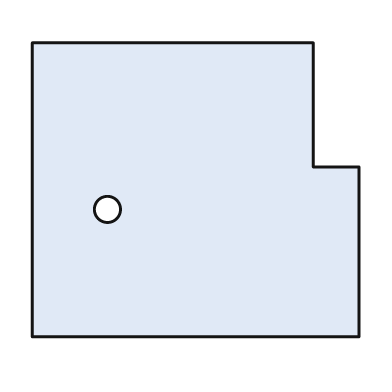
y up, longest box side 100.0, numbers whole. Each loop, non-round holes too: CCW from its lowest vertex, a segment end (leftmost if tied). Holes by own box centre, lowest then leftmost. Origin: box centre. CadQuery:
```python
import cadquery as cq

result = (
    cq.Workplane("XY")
    .moveTo(-50.0, -45.0)
    .lineTo(50.0, -45.0)
    .lineTo(50.0, 7.0)
    .lineTo(36.0, 7.0)
    .lineTo(36.0, 45.0)
    .lineTo(-50.0, 45.0)
    .close()
    .moveTo(-27.0, -6.0)
    .circle(4.0)
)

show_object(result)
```